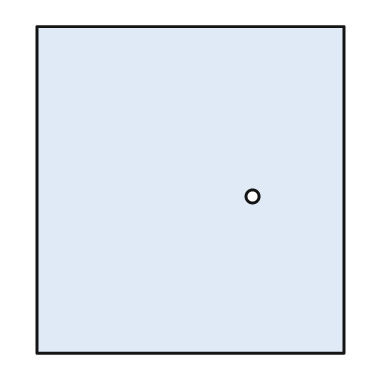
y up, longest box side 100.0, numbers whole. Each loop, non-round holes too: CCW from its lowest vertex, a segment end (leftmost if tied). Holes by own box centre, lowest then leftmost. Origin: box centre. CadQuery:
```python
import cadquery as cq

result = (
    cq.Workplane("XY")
    .moveTo(-47.0, -50.0)
    .lineTo(47.0, -50.0)
    .lineTo(47.0, 50.0)
    .lineTo(-47.0, 50.0)
    .close()
    .moveTo(19.0, -2.0)
    .circle(2.0)
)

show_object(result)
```